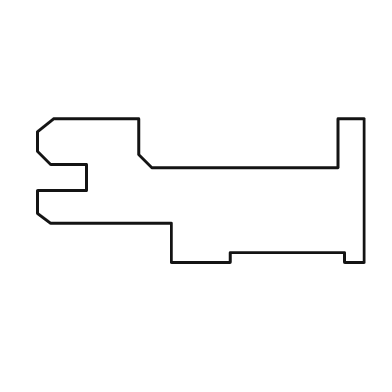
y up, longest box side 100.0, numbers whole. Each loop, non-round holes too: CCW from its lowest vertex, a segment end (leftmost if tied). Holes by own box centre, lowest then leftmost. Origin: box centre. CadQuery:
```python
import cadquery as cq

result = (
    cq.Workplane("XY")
    .moveTo(-9.0, -22.0)
    .lineTo(9.0, -22.0)
    .lineTo(9.0, -19.0)
    .lineTo(44.0, -19.0)
    .lineTo(44.0, -22.0)
    .lineTo(50.0, -22.0)
    .lineTo(50.0, 22.0)
    .lineTo(42.0, 22.0)
    .lineTo(42.0, 7.0)
    .lineTo(-15.0, 7.0)
    .lineTo(-19.0, 11.0)
    .lineTo(-19.0, 22.0)
    .lineTo(-45.0, 22.0)
    .lineTo(-50.0, 18.0)
    .lineTo(-50.0, 12.0)
    .lineTo(-46.0, 8.0)
    .lineTo(-35.0, 8.0)
    .lineTo(-35.0, 0.0)
    .lineTo(-50.0, 0.0)
    .lineTo(-50.0, -7.0)
    .lineTo(-46.0, -10.0)
    .lineTo(-9.0, -10.0)
    .close()
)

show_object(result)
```